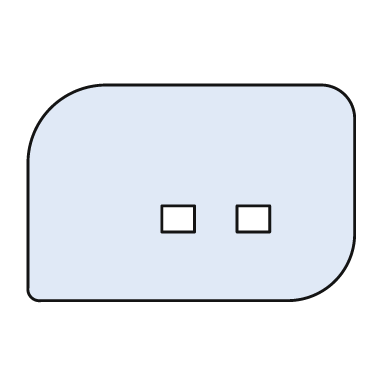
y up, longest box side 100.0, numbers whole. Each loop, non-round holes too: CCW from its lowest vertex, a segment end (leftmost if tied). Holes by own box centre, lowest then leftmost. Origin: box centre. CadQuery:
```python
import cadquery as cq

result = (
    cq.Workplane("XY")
    .moveTo(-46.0, -33.0)
    .lineTo(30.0, -33.0)
    .threePointArc((44.0, -27.0), (50.0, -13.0))
    .lineTo(50.0, 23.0)
    .threePointArc((47.0, 30.0), (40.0, 33.0))
    .lineTo(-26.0, 33.0)
    .threePointArc((-43.0, 26.0), (-50.0, 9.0))
    .lineTo(-50.0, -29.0)
    .threePointArc((-49.0, -32.0), (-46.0, -33.0))
    .close()
    .moveTo(-9.0, -12.0)
    .lineTo(1.0, -12.0)
    .lineTo(1.0, -4.0)
    .lineTo(-9.0, -4.0)
    .close()
    .moveTo(14.0, -12.0)
    .lineTo(24.0, -12.0)
    .lineTo(24.0, -4.0)
    .lineTo(14.0, -4.0)
    .close()
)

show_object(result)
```